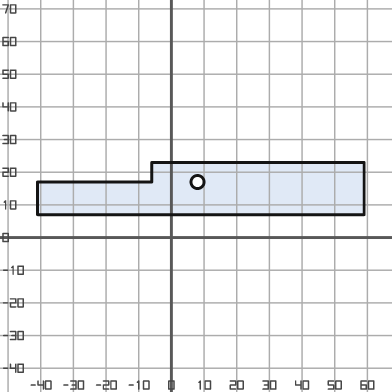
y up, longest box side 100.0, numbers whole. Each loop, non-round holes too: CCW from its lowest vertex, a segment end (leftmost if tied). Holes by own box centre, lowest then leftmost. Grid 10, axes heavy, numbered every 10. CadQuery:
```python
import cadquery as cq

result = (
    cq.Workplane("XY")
    .moveTo(-41.0, 7.0)
    .lineTo(59.0, 7.0)
    .lineTo(59.0, 23.0)
    .lineTo(-6.0, 23.0)
    .lineTo(-6.0, 17.0)
    .lineTo(-41.0, 17.0)
    .close()
    .moveTo(8.0, 17.0)
    .circle(2.0)
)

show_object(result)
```